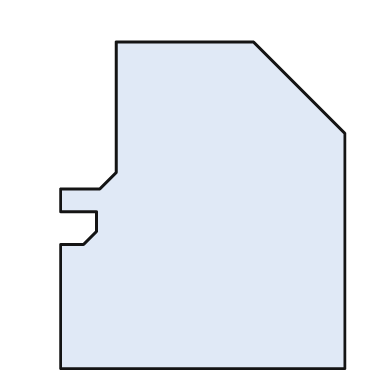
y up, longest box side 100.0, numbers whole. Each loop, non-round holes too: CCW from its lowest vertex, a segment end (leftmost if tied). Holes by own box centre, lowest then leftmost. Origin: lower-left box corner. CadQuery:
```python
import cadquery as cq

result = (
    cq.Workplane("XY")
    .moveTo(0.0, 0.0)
    .lineTo(87.0, 0.0)
    .lineTo(87.0, 72.0)
    .lineTo(59.0, 100.0)
    .lineTo(17.0, 100.0)
    .lineTo(17.0, 60.0)
    .lineTo(12.0, 55.0)
    .lineTo(0.0, 55.0)
    .lineTo(0.0, 48.0)
    .lineTo(11.0, 48.0)
    .lineTo(11.0, 42.0)
    .lineTo(7.0, 38.0)
    .lineTo(0.0, 38.0)
    .close()
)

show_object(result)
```